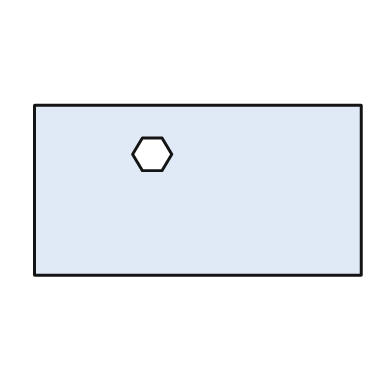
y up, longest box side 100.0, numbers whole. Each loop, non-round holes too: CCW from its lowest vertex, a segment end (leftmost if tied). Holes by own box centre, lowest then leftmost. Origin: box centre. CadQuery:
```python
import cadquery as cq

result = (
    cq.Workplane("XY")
    .moveTo(-50.0, -26.0)
    .lineTo(50.0, -26.0)
    .lineTo(50.0, 26.0)
    .lineTo(-50.0, 26.0)
    .close()
    .moveTo(-17.0, 6.0)
    .lineTo(-11.0, 6.0)
    .lineTo(-8.0, 11.0)
    .lineTo(-11.0, 16.0)
    .lineTo(-17.0, 16.0)
    .lineTo(-20.0, 11.0)
    .close()
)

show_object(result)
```